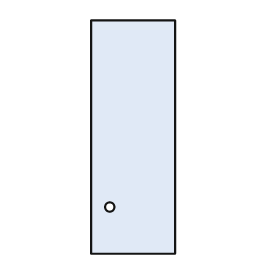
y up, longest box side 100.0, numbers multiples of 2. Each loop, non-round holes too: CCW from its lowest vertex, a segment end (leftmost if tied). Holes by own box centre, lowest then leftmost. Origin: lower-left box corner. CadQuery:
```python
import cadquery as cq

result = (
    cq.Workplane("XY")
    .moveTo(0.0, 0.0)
    .lineTo(36.0, 0.0)
    .lineTo(36.0, 100.0)
    .lineTo(0.0, 100.0)
    .close()
    .moveTo(8.0, 20.0)
    .circle(2.0)
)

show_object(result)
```